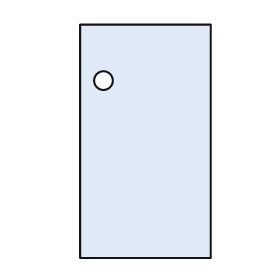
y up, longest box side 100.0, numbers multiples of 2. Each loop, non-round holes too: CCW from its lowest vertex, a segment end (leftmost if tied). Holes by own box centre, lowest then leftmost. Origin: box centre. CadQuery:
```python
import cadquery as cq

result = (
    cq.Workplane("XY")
    .moveTo(-28.0, -50.0)
    .lineTo(28.0, -50.0)
    .lineTo(28.0, 50.0)
    .lineTo(-28.0, 50.0)
    .close()
    .moveTo(-18.0, 26.0)
    .circle(4.0)
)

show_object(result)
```